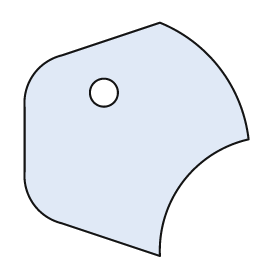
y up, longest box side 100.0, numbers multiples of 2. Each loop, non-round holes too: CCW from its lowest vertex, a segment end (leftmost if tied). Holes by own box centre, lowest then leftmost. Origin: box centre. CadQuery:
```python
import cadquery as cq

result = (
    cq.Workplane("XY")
    .moveTo(10.0, -50.0)
    .threePointArc((20.0, -18.0), (48.0, 0.0))
    .threePointArc((36.0, 30.0), (10.0, 50.0))
    .lineTo(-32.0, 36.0)
    .threePointArc((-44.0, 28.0), (-48.0, 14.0))
    .lineTo(-48.0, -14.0)
    .threePointArc((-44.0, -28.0), (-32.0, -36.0))
    .close()
    .moveTo(-14.0, 20.0)
    .circle(6.0)
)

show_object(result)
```